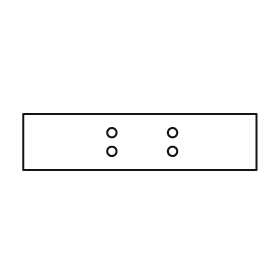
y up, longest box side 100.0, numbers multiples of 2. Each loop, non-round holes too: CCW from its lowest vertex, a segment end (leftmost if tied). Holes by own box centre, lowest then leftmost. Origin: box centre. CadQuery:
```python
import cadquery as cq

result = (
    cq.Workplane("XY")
    .moveTo(-50.0, -12.0)
    .lineTo(50.0, -12.0)
    .lineTo(50.0, 12.0)
    .lineTo(-50.0, 12.0)
    .close()
    .moveTo(-12.0, -4.0)
    .circle(2.0)
    .moveTo(14.0, -4.0)
    .circle(2.0)
    .moveTo(-12.0, 4.0)
    .circle(2.0)
    .moveTo(14.0, 4.0)
    .circle(2.0)
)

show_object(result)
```